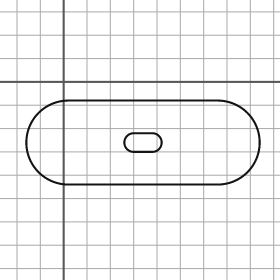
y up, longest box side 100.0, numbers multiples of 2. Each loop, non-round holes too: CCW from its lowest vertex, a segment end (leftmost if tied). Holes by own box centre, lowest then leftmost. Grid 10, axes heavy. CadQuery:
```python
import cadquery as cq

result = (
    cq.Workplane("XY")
    .moveTo(2.0, -44.0)
    .lineTo(66.0, -44.0)
    .threePointArc((84.0, -26.0), (66.0, -8.0))
    .lineTo(2.0, -8.0)
    .threePointArc((-16.0, -26.0), (2.0, -44.0))
    .close()
    .moveTo(30.0, -30.0)
    .lineTo(38.0, -30.0)
    .threePointArc((42.0, -26.0), (38.0, -22.0))
    .lineTo(30.0, -22.0)
    .threePointArc((26.0, -26.0), (30.0, -30.0))
    .close()
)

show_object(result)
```